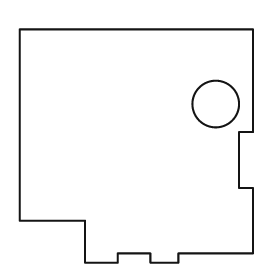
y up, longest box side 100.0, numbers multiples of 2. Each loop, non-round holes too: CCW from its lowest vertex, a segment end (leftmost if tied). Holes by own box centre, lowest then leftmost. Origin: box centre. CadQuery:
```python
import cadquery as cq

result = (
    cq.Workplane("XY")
    .moveTo(-22.0, -50.0)
    .lineTo(-8.0, -50.0)
    .lineTo(-8.0, -46.0)
    .lineTo(6.0, -46.0)
    .lineTo(6.0, -50.0)
    .lineTo(18.0, -50.0)
    .lineTo(18.0, -46.0)
    .lineTo(50.0, -46.0)
    .lineTo(50.0, -18.0)
    .lineTo(44.0, -18.0)
    .lineTo(44.0, 6.0)
    .lineTo(50.0, 6.0)
    .lineTo(50.0, 50.0)
    .lineTo(-50.0, 50.0)
    .lineTo(-50.0, -32.0)
    .lineTo(-22.0, -32.0)
    .close()
    .moveTo(34.0, 18.0)
    .circle(10.0)
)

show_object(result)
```